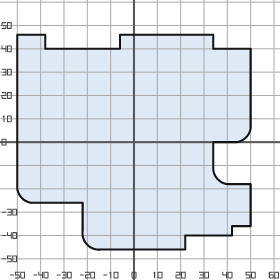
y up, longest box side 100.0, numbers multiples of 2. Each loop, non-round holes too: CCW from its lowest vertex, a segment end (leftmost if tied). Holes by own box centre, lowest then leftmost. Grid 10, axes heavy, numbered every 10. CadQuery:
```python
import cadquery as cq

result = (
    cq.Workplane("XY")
    .moveTo(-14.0, -46.0)
    .lineTo(22.0, -46.0)
    .lineTo(22.0, -40.0)
    .lineTo(42.0, -40.0)
    .lineTo(42.0, -36.0)
    .lineTo(50.0, -36.0)
    .lineTo(50.0, -18.0)
    .lineTo(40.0, -18.0)
    .threePointArc((36.0, -16.0), (34.0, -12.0))
    .lineTo(34.0, 0.0)
    .lineTo(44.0, 0.0)
    .threePointArc((48.0, 2.0), (50.0, 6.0))
    .lineTo(50.0, 40.0)
    .lineTo(34.0, 40.0)
    .lineTo(34.0, 46.0)
    .lineTo(-6.0, 46.0)
    .lineTo(-6.0, 40.0)
    .lineTo(-38.0, 40.0)
    .lineTo(-38.0, 46.0)
    .lineTo(-50.0, 46.0)
    .lineTo(-50.0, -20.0)
    .threePointArc((-48.0, -24.0), (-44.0, -26.0))
    .lineTo(-22.0, -26.0)
    .lineTo(-22.0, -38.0)
    .threePointArc((-20.0, -44.0), (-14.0, -46.0))
    .close()
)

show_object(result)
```